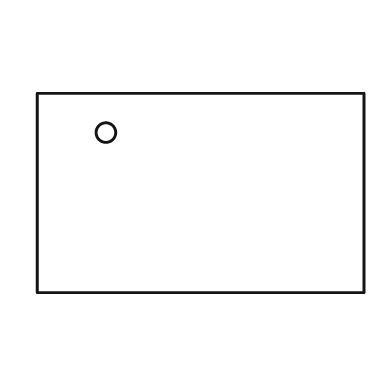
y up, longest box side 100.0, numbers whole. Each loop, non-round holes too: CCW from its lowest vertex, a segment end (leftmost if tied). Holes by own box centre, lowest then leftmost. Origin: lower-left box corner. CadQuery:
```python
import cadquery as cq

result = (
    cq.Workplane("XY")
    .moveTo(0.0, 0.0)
    .lineTo(100.0, 0.0)
    .lineTo(100.0, 61.0)
    .lineTo(0.0, 61.0)
    .close()
    .moveTo(21.0, 49.0)
    .circle(3.0)
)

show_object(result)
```